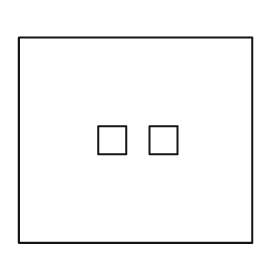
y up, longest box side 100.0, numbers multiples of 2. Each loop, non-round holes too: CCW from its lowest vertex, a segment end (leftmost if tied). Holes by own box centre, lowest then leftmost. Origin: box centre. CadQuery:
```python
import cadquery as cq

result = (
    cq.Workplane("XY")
    .moveTo(-50.0, -44.0)
    .lineTo(50.0, -44.0)
    .lineTo(50.0, 44.0)
    .lineTo(-50.0, 44.0)
    .close()
    .moveTo(-16.0, -6.0)
    .lineTo(-4.0, -6.0)
    .lineTo(-4.0, 6.0)
    .lineTo(-16.0, 6.0)
    .close()
    .moveTo(6.0, -6.0)
    .lineTo(18.0, -6.0)
    .lineTo(18.0, 6.0)
    .lineTo(6.0, 6.0)
    .close()
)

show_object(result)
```